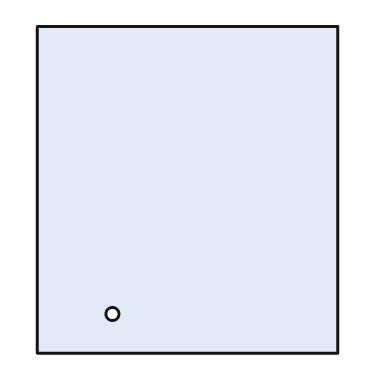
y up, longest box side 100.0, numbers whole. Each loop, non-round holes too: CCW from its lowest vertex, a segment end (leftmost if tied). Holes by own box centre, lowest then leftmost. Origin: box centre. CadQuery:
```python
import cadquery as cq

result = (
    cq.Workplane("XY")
    .moveTo(-46.0, -50.0)
    .lineTo(46.0, -50.0)
    .lineTo(46.0, 50.0)
    .lineTo(-46.0, 50.0)
    .close()
    .moveTo(-23.0, -38.0)
    .circle(2.0)
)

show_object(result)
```